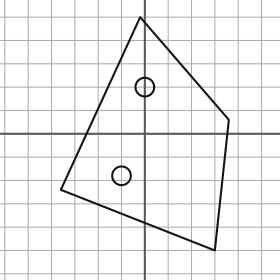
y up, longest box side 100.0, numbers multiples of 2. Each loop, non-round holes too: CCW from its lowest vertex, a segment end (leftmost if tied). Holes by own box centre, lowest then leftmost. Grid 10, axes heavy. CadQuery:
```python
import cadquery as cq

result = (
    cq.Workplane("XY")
    .moveTo(30.0, -50.0)
    .lineTo(36.0, 6.0)
    .lineTo(-2.0, 50.0)
    .lineTo(-36.0, -24.0)
    .close()
    .moveTo(-10.0, -18.0)
    .circle(4.0)
    .moveTo(0.0, 20.0)
    .circle(4.0)
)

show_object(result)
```